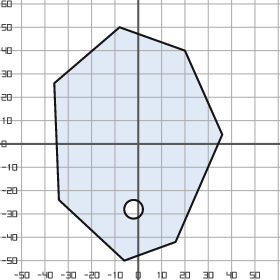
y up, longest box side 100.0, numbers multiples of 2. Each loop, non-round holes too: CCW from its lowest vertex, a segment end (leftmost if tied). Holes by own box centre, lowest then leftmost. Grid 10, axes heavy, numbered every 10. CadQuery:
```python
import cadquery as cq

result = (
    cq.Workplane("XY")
    .moveTo(-6.0, -50.0)
    .lineTo(16.0, -42.0)
    .lineTo(36.0, 4.0)
    .lineTo(20.0, 40.0)
    .lineTo(-8.0, 50.0)
    .lineTo(-36.0, 26.0)
    .lineTo(-34.0, -24.0)
    .close()
    .moveTo(-2.0, -28.0)
    .circle(4.0)
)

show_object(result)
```